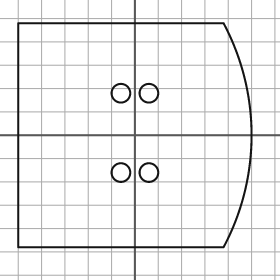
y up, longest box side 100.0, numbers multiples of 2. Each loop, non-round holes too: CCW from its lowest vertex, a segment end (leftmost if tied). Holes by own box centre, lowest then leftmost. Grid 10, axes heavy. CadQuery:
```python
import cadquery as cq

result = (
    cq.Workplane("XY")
    .moveTo(-50.0, -48.0)
    .lineTo(38.0, -48.0)
    .threePointArc((50.0, 0.0), (38.0, 48.0))
    .lineTo(-50.0, 48.0)
    .close()
    .moveTo(-6.0, -16.0)
    .circle(4.0)
    .moveTo(6.0, -16.0)
    .circle(4.0)
    .moveTo(-6.0, 18.0)
    .circle(4.0)
    .moveTo(6.0, 18.0)
    .circle(4.0)
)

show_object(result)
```